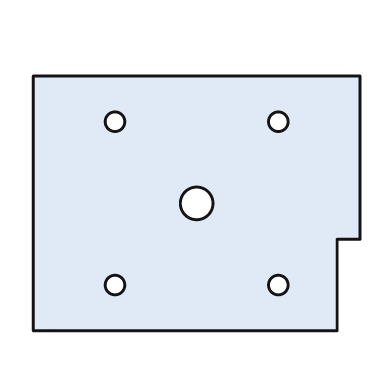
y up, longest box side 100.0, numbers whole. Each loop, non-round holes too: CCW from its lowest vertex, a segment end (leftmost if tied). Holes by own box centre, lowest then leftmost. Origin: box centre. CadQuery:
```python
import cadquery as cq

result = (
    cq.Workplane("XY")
    .moveTo(-50.0, -39.0)
    .lineTo(43.0, -39.0)
    .lineTo(43.0, -11.0)
    .lineTo(50.0, -11.0)
    .lineTo(50.0, 39.0)
    .lineTo(-50.0, 39.0)
    .close()
    .moveTo(-25.0, -25.0)
    .circle(3.0)
    .moveTo(25.0, -25.0)
    .circle(3.0)
    .moveTo(0.0, 0.0)
    .circle(5.0)
    .moveTo(-25.0, 25.0)
    .circle(3.0)
    .moveTo(25.0, 25.0)
    .circle(3.0)
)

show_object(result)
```